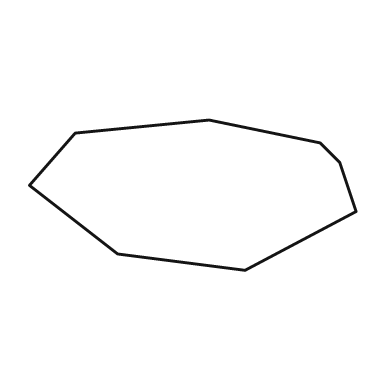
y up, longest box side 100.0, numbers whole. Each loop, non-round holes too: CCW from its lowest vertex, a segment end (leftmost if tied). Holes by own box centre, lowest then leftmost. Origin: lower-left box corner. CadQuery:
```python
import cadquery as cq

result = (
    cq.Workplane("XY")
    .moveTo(66.0, 0.0)
    .lineTo(100.0, 18.0)
    .lineTo(95.0, 33.0)
    .lineTo(89.0, 39.0)
    .lineTo(55.0, 46.0)
    .lineTo(14.0, 42.0)
    .lineTo(0.0, 26.0)
    .lineTo(27.0, 5.0)
    .close()
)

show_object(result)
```